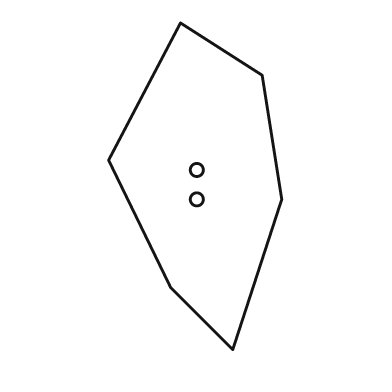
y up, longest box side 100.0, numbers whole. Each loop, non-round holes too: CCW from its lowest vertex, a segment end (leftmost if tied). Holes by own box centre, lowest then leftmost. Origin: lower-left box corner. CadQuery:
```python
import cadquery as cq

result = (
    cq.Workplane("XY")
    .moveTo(38.0, 0.0)
    .lineTo(53.0, 46.0)
    .lineTo(47.0, 84.0)
    .lineTo(22.0, 100.0)
    .lineTo(0.0, 58.0)
    .lineTo(19.0, 19.0)
    .close()
    .moveTo(27.0, 46.0)
    .circle(2.0)
    .moveTo(27.0, 55.0)
    .circle(2.0)
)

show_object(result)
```